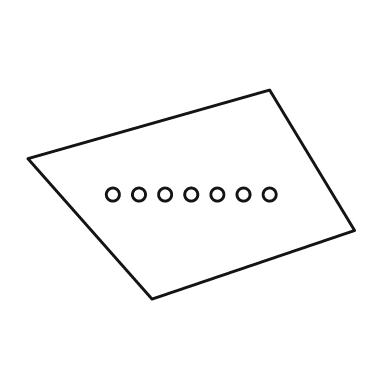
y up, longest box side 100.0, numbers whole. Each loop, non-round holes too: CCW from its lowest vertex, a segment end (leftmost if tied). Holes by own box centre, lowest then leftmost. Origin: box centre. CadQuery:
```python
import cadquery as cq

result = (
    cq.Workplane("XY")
    .moveTo(-12.0, -32.0)
    .lineTo(50.0, -11.0)
    .lineTo(24.0, 32.0)
    .lineTo(-50.0, 11.0)
    .close()
    .moveTo(-24.0, 0.0)
    .circle(2.0)
    .moveTo(-16.0, 0.0)
    .circle(2.0)
    .moveTo(-8.0, 0.0)
    .circle(2.0)
    .moveTo(0.0, 0.0)
    .circle(2.0)
    .moveTo(8.0, 0.0)
    .circle(2.0)
    .moveTo(16.0, 0.0)
    .circle(2.0)
    .moveTo(24.0, 0.0)
    .circle(2.0)
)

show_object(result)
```